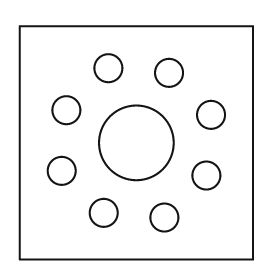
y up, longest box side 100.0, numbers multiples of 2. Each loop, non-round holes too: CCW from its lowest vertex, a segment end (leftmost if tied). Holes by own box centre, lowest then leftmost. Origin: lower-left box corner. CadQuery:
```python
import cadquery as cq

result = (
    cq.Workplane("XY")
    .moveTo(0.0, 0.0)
    .lineTo(100.0, 0.0)
    .lineTo(100.0, 100.0)
    .lineTo(0.0, 100.0)
    .close()
    .moveTo(62.0, 18.0)
    .circle(6.0)
    .moveTo(36.0, 20.0)
    .circle(6.0)
    .moveTo(80.0, 36.0)
    .circle(6.0)
    .moveTo(18.0, 38.0)
    .circle(6.0)
    .moveTo(50.0, 50.0)
    .circle(16.0)
    .moveTo(82.0, 62.0)
    .circle(6.0)
    .moveTo(20.0, 64.0)
    .circle(6.0)
    .moveTo(64.0, 80.0)
    .circle(6.0)
    .moveTo(38.0, 82.0)
    .circle(6.0)
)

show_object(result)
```